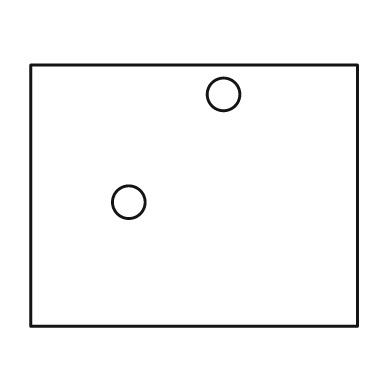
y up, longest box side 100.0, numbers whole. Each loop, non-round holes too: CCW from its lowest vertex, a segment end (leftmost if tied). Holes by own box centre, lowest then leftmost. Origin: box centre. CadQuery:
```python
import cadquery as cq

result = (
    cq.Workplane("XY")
    .moveTo(-50.0, -40.0)
    .lineTo(50.0, -40.0)
    .lineTo(50.0, 40.0)
    .lineTo(-50.0, 40.0)
    .close()
    .moveTo(-20.0, -2.0)
    .circle(5.0)
    .moveTo(9.0, 31.0)
    .circle(5.0)
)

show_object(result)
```